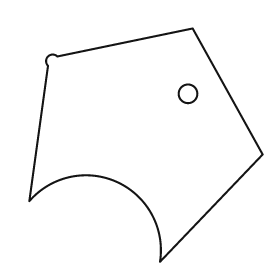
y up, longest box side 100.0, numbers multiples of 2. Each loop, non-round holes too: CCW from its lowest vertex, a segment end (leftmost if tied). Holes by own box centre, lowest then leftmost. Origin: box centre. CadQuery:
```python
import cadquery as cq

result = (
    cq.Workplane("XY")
    .moveTo(6.0, -50.0)
    .lineTo(50.0, -4.0)
    .lineTo(20.0, 50.0)
    .lineTo(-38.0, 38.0)
    .threePointArc((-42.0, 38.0), (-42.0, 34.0))
    .lineTo(-50.0, -24.0)
    .threePointArc((-12.0, -16.0), (6.0, -50.0))
    .close()
    .moveTo(18.0, 22.0)
    .circle(4.0)
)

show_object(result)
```